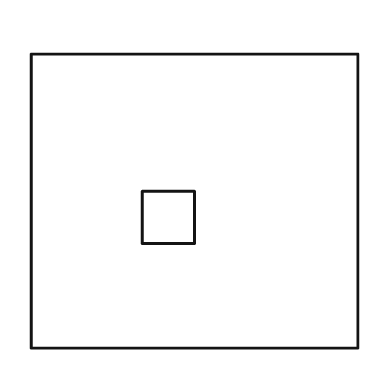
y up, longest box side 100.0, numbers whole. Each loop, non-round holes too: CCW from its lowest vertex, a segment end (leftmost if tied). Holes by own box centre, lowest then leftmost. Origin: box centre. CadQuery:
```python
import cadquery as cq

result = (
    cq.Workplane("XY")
    .moveTo(-50.0, -45.0)
    .lineTo(50.0, -45.0)
    .lineTo(50.0, 45.0)
    .lineTo(-50.0, 45.0)
    .close()
    .moveTo(-16.0, -13.0)
    .lineTo(0.0, -13.0)
    .lineTo(0.0, 3.0)
    .lineTo(-16.0, 3.0)
    .close()
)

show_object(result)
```